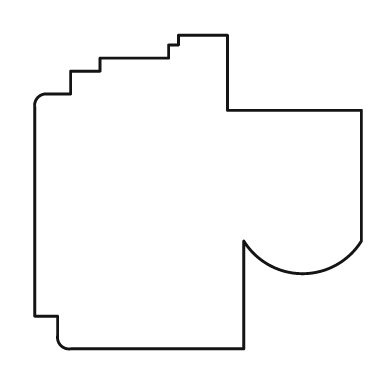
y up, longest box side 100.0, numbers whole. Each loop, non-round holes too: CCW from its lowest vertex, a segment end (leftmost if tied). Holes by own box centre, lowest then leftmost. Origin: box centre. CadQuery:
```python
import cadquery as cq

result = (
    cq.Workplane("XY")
    .moveTo(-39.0, -48.0)
    .lineTo(14.0, -48.0)
    .lineTo(14.0, -15.0)
    .threePointArc((32.0, -25.0), (50.0, -15.0))
    .lineTo(50.0, 25.0)
    .lineTo(9.0, 25.0)
    .lineTo(9.0, 48.0)
    .lineTo(-6.0, 48.0)
    .lineTo(-6.0, 45.0)
    .lineTo(-9.0, 45.0)
    .lineTo(-9.0, 41.0)
    .lineTo(-30.0, 41.0)
    .lineTo(-30.0, 37.0)
    .lineTo(-39.0, 37.0)
    .lineTo(-39.0, 30.0)
    .lineTo(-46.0, 30.0)
    .threePointArc((-49.0, 29.0), (-50.0, 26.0))
    .lineTo(-50.0, -38.0)
    .lineTo(-43.0, -38.0)
    .lineTo(-43.0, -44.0)
    .threePointArc((-42.0, -47.0), (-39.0, -48.0))
    .close()
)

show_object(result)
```